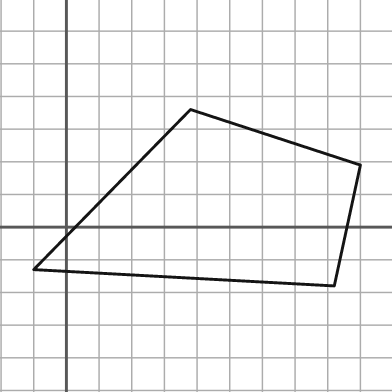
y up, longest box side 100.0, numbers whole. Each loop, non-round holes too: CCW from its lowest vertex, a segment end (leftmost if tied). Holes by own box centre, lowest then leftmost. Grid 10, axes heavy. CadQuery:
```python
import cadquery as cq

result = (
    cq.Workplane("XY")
    .moveTo(82.0, -18.0)
    .lineTo(90.0, 19.0)
    .lineTo(38.0, 36.0)
    .lineTo(-10.0, -13.0)
    .close()
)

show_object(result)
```